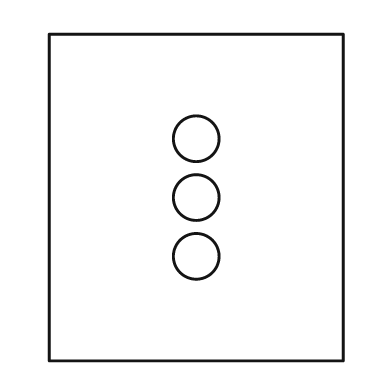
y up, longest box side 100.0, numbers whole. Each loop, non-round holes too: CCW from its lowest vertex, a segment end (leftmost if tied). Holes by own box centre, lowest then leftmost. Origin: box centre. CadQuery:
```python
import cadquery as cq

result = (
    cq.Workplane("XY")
    .moveTo(-45.0, -50.0)
    .lineTo(45.0, -50.0)
    .lineTo(45.0, 50.0)
    .lineTo(-45.0, 50.0)
    .close()
    .moveTo(0.0, -18.0)
    .circle(7.0)
    .moveTo(0.0, 0.0)
    .circle(7.0)
    .moveTo(0.0, 18.0)
    .circle(7.0)
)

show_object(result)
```